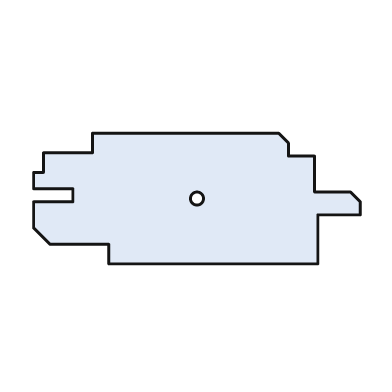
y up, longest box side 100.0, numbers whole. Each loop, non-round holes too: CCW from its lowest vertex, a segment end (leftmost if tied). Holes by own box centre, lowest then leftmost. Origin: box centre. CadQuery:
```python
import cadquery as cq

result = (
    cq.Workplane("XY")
    .moveTo(-27.0, -20.0)
    .lineTo(37.0, -20.0)
    .lineTo(37.0, -5.0)
    .lineTo(50.0, -5.0)
    .lineTo(50.0, -1.0)
    .lineTo(47.0, 2.0)
    .lineTo(36.0, 2.0)
    .lineTo(36.0, 13.0)
    .lineTo(28.0, 13.0)
    .lineTo(28.0, 17.0)
    .lineTo(25.0, 20.0)
    .lineTo(-32.0, 20.0)
    .lineTo(-32.0, 14.0)
    .lineTo(-47.0, 14.0)
    .lineTo(-47.0, 8.0)
    .lineTo(-50.0, 8.0)
    .lineTo(-50.0, 3.0)
    .lineTo(-38.0, 3.0)
    .lineTo(-38.0, -1.0)
    .lineTo(-50.0, -1.0)
    .lineTo(-50.0, -9.0)
    .lineTo(-45.0, -14.0)
    .lineTo(-27.0, -14.0)
    .close()
    .moveTo(0.0, 0.0)
    .circle(2.0)
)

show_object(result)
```